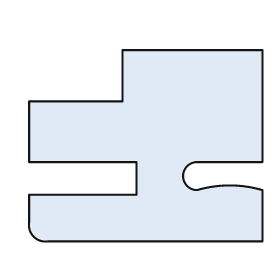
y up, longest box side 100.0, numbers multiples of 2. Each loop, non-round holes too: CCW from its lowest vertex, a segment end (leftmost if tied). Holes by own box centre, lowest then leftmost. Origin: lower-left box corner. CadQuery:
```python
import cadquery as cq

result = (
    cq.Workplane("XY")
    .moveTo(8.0, 0.0)
    .lineTo(100.0, 0.0)
    .lineTo(100.0, 22.0)
    .threePointArc((86.0, 24.0), (72.0, 22.0))
    .threePointArc((66.0, 28.0), (72.0, 34.0))
    .lineTo(100.0, 34.0)
    .lineTo(100.0, 82.0)
    .lineTo(40.0, 82.0)
    .lineTo(40.0, 60.0)
    .lineTo(0.0, 60.0)
    .lineTo(0.0, 34.0)
    .lineTo(46.0, 34.0)
    .lineTo(46.0, 20.0)
    .lineTo(0.0, 20.0)
    .lineTo(0.0, 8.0)
    .threePointArc((2.0, 2.0), (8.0, 0.0))
    .close()
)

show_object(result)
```